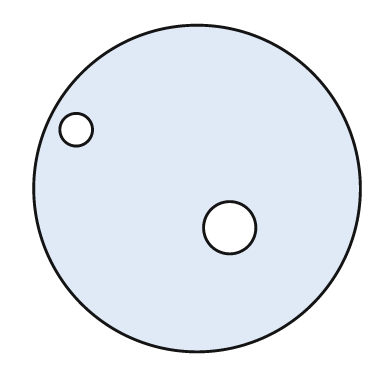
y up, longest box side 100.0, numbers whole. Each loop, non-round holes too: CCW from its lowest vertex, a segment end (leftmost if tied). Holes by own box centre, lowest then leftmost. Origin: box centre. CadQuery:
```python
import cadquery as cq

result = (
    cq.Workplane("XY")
    .moveTo(0.0, 0.0)
    .circle(50.0)
    .moveTo(10.0, -12.0)
    .circle(8.0)
    .moveTo(-37.0, 18.0)
    .circle(5.0)
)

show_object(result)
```